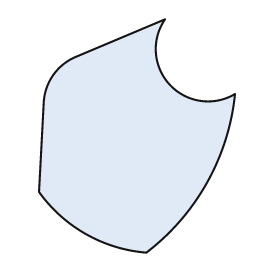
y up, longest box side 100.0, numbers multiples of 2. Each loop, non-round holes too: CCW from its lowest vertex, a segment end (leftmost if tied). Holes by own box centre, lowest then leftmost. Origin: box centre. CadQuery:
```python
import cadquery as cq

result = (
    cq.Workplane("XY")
    .moveTo(4.0, -50.0)
    .threePointArc((30.0, -20.0), (42.0, 18.0))
    .threePointArc((14.0, 22.0), (12.0, 50.0))
    .lineTo(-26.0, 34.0)
    .threePointArc((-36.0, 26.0), (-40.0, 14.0))
    .lineTo(-42.0, -24.0)
    .threePointArc((-22.0, -42.0), (4.0, -50.0))
    .close()
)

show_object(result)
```